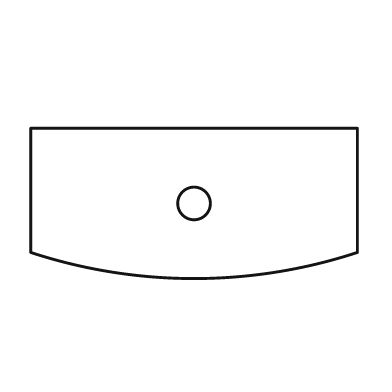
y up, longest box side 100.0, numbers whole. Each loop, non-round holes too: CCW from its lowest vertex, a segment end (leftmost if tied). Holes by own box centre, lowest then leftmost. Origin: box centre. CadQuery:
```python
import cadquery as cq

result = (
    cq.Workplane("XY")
    .moveTo(-50.0, -15.0)
    .threePointArc((0.0, -23.0), (50.0, -15.0))
    .lineTo(50.0, 23.0)
    .lineTo(-50.0, 23.0)
    .close()
    .moveTo(0.0, 0.0)
    .circle(5.0)
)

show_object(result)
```